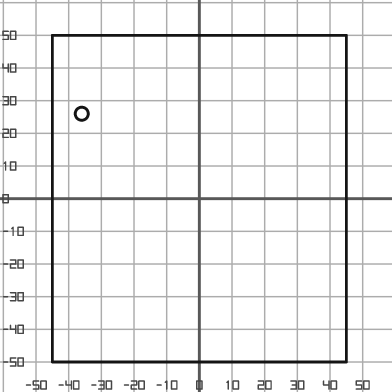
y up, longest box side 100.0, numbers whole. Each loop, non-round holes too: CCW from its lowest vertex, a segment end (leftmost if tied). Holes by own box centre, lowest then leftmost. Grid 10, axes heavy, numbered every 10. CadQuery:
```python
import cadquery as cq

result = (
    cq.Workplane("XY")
    .moveTo(-45.0, -50.0)
    .lineTo(45.0, -50.0)
    .lineTo(45.0, 50.0)
    .lineTo(-45.0, 50.0)
    .close()
    .moveTo(-36.0, 26.0)
    .circle(2.0)
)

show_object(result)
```